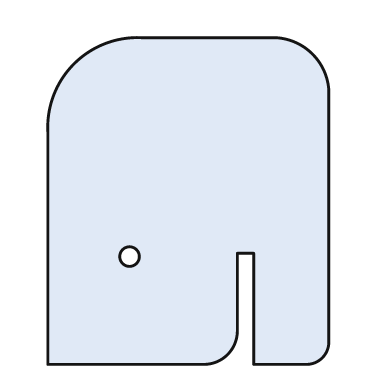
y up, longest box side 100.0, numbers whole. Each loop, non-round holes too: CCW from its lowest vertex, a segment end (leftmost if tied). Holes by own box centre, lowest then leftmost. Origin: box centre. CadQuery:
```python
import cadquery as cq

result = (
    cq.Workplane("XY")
    .moveTo(-43.0, -50.0)
    .lineTo(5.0, -50.0)
    .threePointArc((12.0, -47.0), (15.0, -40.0))
    .lineTo(15.0, -16.0)
    .lineTo(20.0, -16.0)
    .lineTo(20.0, -50.0)
    .lineTo(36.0, -50.0)
    .threePointArc((41.0, -48.0), (43.0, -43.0))
    .lineTo(43.0, 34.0)
    .threePointArc((38.0, 45.0), (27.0, 50.0))
    .lineTo(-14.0, 50.0)
    .threePointArc((-35.0, 42.0), (-43.0, 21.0))
    .close()
    .moveTo(-18.0, -17.0)
    .circle(3.0)
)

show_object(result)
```